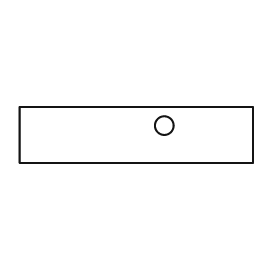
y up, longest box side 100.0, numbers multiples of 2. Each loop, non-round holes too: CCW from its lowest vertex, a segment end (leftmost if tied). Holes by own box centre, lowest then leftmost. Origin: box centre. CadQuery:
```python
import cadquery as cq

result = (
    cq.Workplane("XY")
    .moveTo(-50.0, -12.0)
    .lineTo(50.0, -12.0)
    .lineTo(50.0, 12.0)
    .lineTo(-50.0, 12.0)
    .close()
    .moveTo(12.0, 4.0)
    .circle(4.0)
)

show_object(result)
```